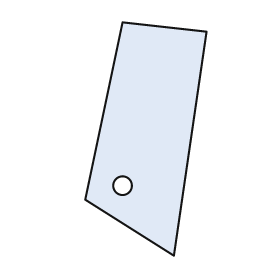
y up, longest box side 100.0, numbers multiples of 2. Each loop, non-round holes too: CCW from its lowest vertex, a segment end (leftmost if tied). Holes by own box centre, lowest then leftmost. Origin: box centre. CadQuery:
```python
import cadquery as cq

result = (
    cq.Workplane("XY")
    .moveTo(12.0, -50.0)
    .lineTo(26.0, 46.0)
    .lineTo(-10.0, 50.0)
    .lineTo(-26.0, -26.0)
    .close()
    .moveTo(-10.0, -20.0)
    .circle(4.0)
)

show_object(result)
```